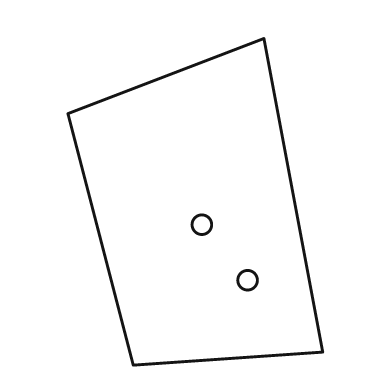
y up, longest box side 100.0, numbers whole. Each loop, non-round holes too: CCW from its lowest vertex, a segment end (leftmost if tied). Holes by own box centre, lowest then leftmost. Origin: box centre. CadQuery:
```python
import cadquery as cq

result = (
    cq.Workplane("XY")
    .moveTo(-19.0, -50.0)
    .lineTo(39.0, -46.0)
    .lineTo(21.0, 50.0)
    .lineTo(-39.0, 27.0)
    .close()
    .moveTo(16.0, -24.0)
    .circle(3.0)
    .moveTo(2.0, -7.0)
    .circle(3.0)
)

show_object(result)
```